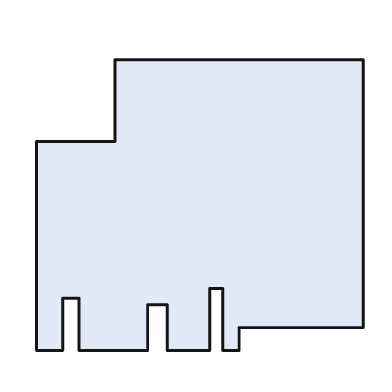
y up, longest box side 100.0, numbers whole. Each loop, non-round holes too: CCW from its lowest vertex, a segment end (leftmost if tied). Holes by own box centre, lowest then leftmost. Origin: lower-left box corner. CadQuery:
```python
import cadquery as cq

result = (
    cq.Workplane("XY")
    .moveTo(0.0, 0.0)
    .lineTo(8.0, 0.0)
    .lineTo(8.0, 16.0)
    .lineTo(13.0, 16.0)
    .lineTo(13.0, 0.0)
    .lineTo(34.0, 0.0)
    .lineTo(34.0, 14.0)
    .lineTo(40.0, 14.0)
    .lineTo(40.0, 0.0)
    .lineTo(53.0, 0.0)
    .lineTo(53.0, 19.0)
    .lineTo(57.0, 19.0)
    .lineTo(57.0, 0.0)
    .lineTo(62.0, 0.0)
    .lineTo(62.0, 7.0)
    .lineTo(100.0, 7.0)
    .lineTo(100.0, 89.0)
    .lineTo(24.0, 89.0)
    .lineTo(24.0, 64.0)
    .lineTo(0.0, 64.0)
    .close()
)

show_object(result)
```